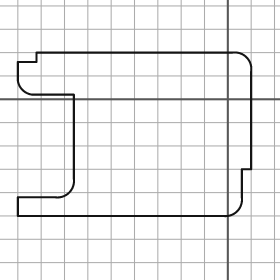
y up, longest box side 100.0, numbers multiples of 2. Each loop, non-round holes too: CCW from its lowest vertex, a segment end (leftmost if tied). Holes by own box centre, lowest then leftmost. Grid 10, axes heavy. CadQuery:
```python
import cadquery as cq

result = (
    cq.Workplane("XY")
    .moveTo(-90.0, -50.0)
    .lineTo(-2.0, -50.0)
    .threePointArc((4.0, -48.0), (6.0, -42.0))
    .lineTo(6.0, -30.0)
    .lineTo(10.0, -30.0)
    .lineTo(10.0, 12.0)
    .threePointArc((8.0, 18.0), (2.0, 20.0))
    .lineTo(-82.0, 20.0)
    .lineTo(-82.0, 16.0)
    .lineTo(-90.0, 16.0)
    .lineTo(-90.0, 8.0)
    .threePointArc((-88.0, 4.0), (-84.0, 2.0))
    .lineTo(-66.0, 2.0)
    .lineTo(-66.0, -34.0)
    .threePointArc((-68.0, -40.0), (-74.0, -42.0))
    .lineTo(-90.0, -42.0)
    .close()
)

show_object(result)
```